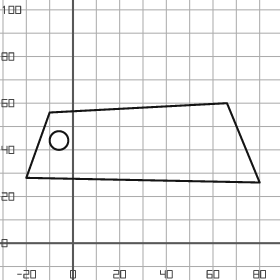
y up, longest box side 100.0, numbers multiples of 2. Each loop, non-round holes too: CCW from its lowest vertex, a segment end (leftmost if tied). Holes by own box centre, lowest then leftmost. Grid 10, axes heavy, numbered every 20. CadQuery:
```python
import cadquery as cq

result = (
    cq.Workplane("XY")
    .moveTo(80.0, 26.0)
    .lineTo(66.0, 60.0)
    .lineTo(-10.0, 56.0)
    .lineTo(-20.0, 28.0)
    .close()
    .moveTo(-6.0, 44.0)
    .circle(4.0)
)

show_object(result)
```